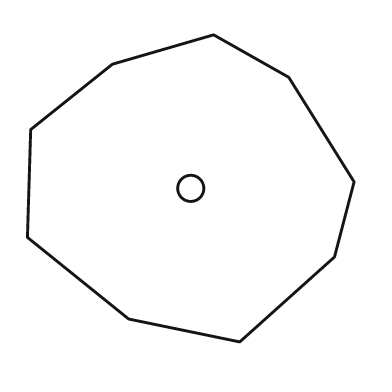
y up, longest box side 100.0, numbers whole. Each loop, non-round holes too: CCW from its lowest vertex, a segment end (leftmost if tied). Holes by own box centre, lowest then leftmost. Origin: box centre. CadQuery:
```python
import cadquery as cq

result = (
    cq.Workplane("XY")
    .moveTo(15.0, -47.0)
    .lineTo(44.0, -21.0)
    .lineTo(50.0, 2.0)
    .lineTo(30.0, 34.0)
    .lineTo(7.0, 47.0)
    .lineTo(-24.0, 38.0)
    .lineTo(-49.0, 18.0)
    .lineTo(-50.0, -15.0)
    .lineTo(-19.0, -40.0)
    .close()
    .moveTo(0.0, 0.0)
    .circle(4.0)
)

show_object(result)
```